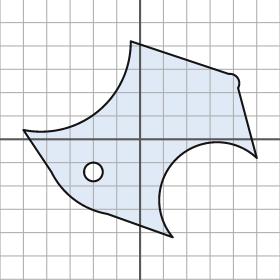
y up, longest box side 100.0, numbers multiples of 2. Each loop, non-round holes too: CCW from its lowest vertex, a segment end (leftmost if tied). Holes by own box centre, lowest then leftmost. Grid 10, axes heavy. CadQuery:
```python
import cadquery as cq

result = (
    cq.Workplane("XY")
    .moveTo(14.0, -42.0)
    .threePointArc((16.0, -8.0), (50.0, -8.0))
    .lineTo(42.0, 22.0)
    .threePointArc((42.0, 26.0), (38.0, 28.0))
    .lineTo(-4.0, 42.0)
    .threePointArc((-18.0, 12.0), (-50.0, 4.0))
    .lineTo(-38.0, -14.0)
    .threePointArc((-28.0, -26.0), (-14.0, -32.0))
    .close()
    .moveTo(-20.0, -14.0)
    .circle(4.0)
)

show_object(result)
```